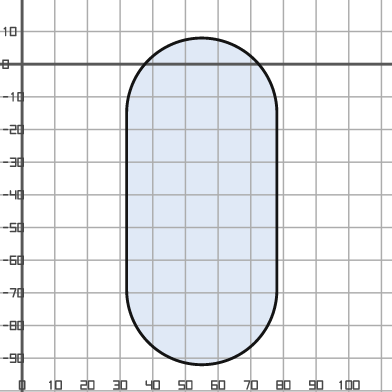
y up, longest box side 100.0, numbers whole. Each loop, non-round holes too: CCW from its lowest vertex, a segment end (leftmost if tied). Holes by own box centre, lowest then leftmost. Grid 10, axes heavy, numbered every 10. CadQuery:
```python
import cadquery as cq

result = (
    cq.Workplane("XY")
    .moveTo(32.0, -69.0)
    .threePointArc((55.0, -92.0), (78.0, -69.0))
    .lineTo(78.0, -15.0)
    .threePointArc((55.0, 8.0), (32.0, -15.0))
    .close()
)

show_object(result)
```